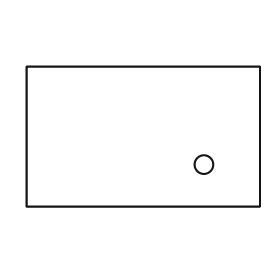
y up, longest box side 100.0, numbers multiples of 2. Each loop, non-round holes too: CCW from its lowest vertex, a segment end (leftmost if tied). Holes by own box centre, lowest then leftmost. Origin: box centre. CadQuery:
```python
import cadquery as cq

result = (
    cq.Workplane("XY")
    .moveTo(-50.0, -30.0)
    .lineTo(50.0, -30.0)
    .lineTo(50.0, 30.0)
    .lineTo(-50.0, 30.0)
    .close()
    .moveTo(26.0, -12.0)
    .circle(4.0)
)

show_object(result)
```